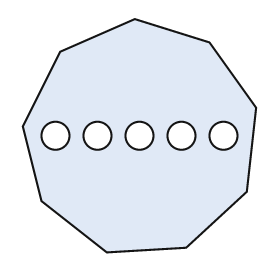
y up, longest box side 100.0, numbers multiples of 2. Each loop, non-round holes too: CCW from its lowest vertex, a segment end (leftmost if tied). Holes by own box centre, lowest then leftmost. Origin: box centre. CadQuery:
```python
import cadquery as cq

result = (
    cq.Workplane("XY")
    .moveTo(-14.0, -50.0)
    .lineTo(20.0, -48.0)
    .lineTo(46.0, -24.0)
    .lineTo(50.0, 12.0)
    .lineTo(30.0, 40.0)
    .lineTo(-2.0, 50.0)
    .lineTo(-34.0, 36.0)
    .lineTo(-50.0, 4.0)
    .lineTo(-42.0, -28.0)
    .close()
    .moveTo(-36.0, 0.0)
    .circle(6.0)
    .moveTo(-18.0, 0.0)
    .circle(6.0)
    .moveTo(0.0, 0.0)
    .circle(6.0)
    .moveTo(18.0, 0.0)
    .circle(6.0)
    .moveTo(36.0, 0.0)
    .circle(6.0)
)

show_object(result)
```